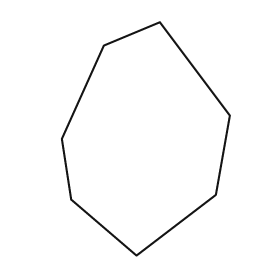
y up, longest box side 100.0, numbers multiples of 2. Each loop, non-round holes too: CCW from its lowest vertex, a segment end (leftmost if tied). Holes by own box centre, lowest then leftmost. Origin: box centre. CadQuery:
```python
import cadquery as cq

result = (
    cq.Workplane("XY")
    .moveTo(-4.0, -50.0)
    .lineTo(30.0, -24.0)
    .lineTo(36.0, 10.0)
    .lineTo(6.0, 50.0)
    .lineTo(-18.0, 40.0)
    .lineTo(-36.0, 0.0)
    .lineTo(-32.0, -26.0)
    .close()
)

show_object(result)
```